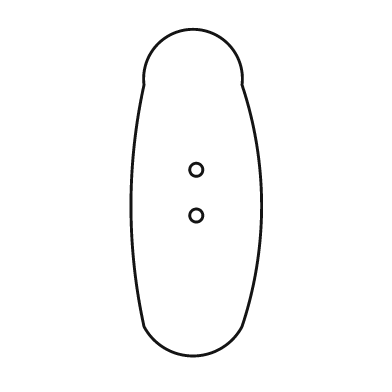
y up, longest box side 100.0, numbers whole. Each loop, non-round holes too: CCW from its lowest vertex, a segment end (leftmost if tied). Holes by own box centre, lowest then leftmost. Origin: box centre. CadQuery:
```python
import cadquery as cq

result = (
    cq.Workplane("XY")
    .moveTo(-16.0, -41.0)
    .threePointArc((-1.0, -50.0), (14.0, -41.0))
    .threePointArc((20.0, -4.0), (14.0, 33.0))
    .threePointArc((-1.0, 50.0), (-16.0, 33.0))
    .threePointArc((-20.0, -4.0), (-16.0, -41.0))
    .close()
    .moveTo(0.0, -7.0)
    .circle(2.0)
    .moveTo(0.0, 7.0)
    .circle(2.0)
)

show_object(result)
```